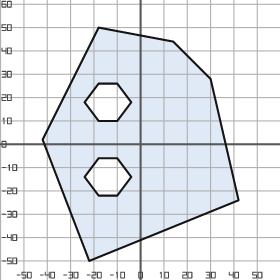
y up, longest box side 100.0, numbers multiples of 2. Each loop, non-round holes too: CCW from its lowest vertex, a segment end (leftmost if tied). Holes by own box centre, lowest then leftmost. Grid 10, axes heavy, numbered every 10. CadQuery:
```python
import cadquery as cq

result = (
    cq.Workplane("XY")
    .moveTo(-22.0, -50.0)
    .lineTo(42.0, -24.0)
    .lineTo(30.0, 28.0)
    .lineTo(14.0, 44.0)
    .lineTo(-18.0, 50.0)
    .lineTo(-42.0, 2.0)
    .close()
    .moveTo(-18.0, -22.0)
    .lineTo(-10.0, -22.0)
    .lineTo(-4.0, -14.0)
    .lineTo(-10.0, -6.0)
    .lineTo(-18.0, -6.0)
    .lineTo(-24.0, -14.0)
    .close()
    .moveTo(-18.0, 10.0)
    .lineTo(-10.0, 10.0)
    .lineTo(-4.0, 18.0)
    .lineTo(-10.0, 26.0)
    .lineTo(-18.0, 26.0)
    .lineTo(-24.0, 18.0)
    .close()
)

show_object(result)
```